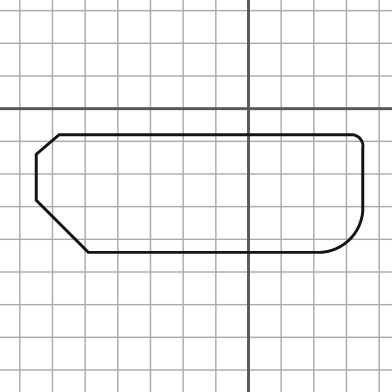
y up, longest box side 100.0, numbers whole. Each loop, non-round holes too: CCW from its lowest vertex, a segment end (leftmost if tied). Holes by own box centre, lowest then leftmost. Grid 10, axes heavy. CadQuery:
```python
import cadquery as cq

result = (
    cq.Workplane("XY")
    .moveTo(-49.0, -44.0)
    .lineTo(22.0, -44.0)
    .threePointArc((31.0, -40.0), (35.0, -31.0))
    .lineTo(35.0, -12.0)
    .threePointArc((34.0, -9.0), (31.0, -8.0))
    .lineTo(-58.0, -8.0)
    .lineTo(-65.0, -14.0)
    .lineTo(-65.0, -28.0)
    .close()
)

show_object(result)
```